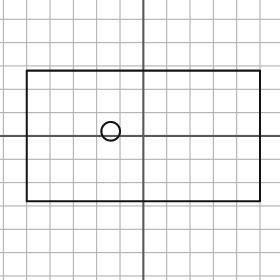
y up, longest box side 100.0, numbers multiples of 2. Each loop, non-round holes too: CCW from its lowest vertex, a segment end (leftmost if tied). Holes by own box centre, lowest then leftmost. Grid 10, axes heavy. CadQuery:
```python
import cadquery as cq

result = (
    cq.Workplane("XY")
    .moveTo(-50.0, -28.0)
    .lineTo(50.0, -28.0)
    .lineTo(50.0, 28.0)
    .lineTo(-50.0, 28.0)
    .close()
    .moveTo(-14.0, 2.0)
    .circle(4.0)
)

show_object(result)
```